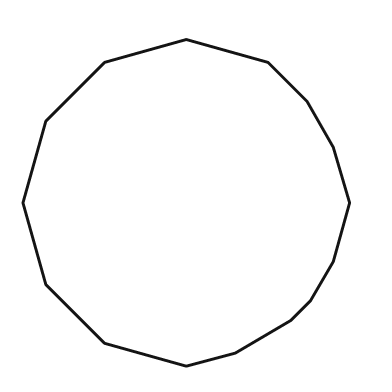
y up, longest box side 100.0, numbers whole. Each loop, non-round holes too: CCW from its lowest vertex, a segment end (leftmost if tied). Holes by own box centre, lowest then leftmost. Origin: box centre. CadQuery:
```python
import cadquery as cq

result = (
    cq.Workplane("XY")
    .moveTo(0.0, -50.0)
    .lineTo(15.0, -46.0)
    .lineTo(32.0, -36.0)
    .lineTo(38.0, -30.0)
    .lineTo(45.0, -18.0)
    .lineTo(50.0, 0.0)
    .lineTo(45.0, 17.0)
    .lineTo(37.0, 31.0)
    .lineTo(25.0, 43.0)
    .lineTo(0.0, 50.0)
    .lineTo(-25.0, 43.0)
    .lineTo(-43.0, 25.0)
    .lineTo(-50.0, 0.0)
    .lineTo(-43.0, -25.0)
    .lineTo(-25.0, -43.0)
    .close()
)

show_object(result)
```